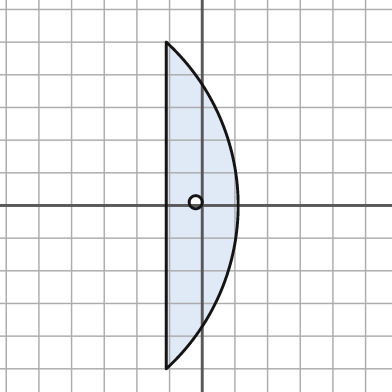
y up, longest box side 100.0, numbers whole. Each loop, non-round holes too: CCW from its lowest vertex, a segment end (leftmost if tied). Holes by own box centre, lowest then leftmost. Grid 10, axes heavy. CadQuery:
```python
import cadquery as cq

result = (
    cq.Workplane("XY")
    .moveTo(-11.0, -50.0)
    .threePointArc((11.0, 0.0), (-11.0, 50.0))
    .close()
    .moveTo(-2.0, 1.0)
    .circle(2.0)
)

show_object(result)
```